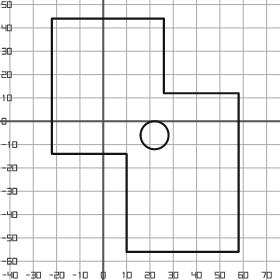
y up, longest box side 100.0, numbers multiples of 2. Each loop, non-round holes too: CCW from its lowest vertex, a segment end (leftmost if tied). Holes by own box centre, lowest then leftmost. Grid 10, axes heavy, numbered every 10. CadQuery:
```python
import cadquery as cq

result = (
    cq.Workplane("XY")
    .moveTo(10.0, -56.0)
    .lineTo(58.0, -56.0)
    .lineTo(58.0, 12.0)
    .lineTo(26.0, 12.0)
    .lineTo(26.0, 44.0)
    .lineTo(-22.0, 44.0)
    .lineTo(-22.0, -14.0)
    .lineTo(10.0, -14.0)
    .close()
    .moveTo(22.0, -6.0)
    .circle(6.0)
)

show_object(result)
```